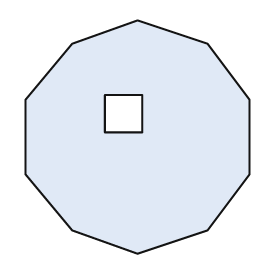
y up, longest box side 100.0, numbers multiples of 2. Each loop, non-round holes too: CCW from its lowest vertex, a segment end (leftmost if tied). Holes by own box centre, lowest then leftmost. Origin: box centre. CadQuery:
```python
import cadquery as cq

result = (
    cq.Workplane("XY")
    .moveTo(0.0, -50.0)
    .lineTo(30.0, -40.0)
    .lineTo(48.0, -16.0)
    .lineTo(48.0, 16.0)
    .lineTo(30.0, 40.0)
    .lineTo(0.0, 50.0)
    .lineTo(-28.0, 40.0)
    .lineTo(-48.0, 16.0)
    .lineTo(-48.0, -16.0)
    .lineTo(-28.0, -40.0)
    .close()
    .moveTo(-14.0, 2.0)
    .lineTo(2.0, 2.0)
    .lineTo(2.0, 18.0)
    .lineTo(-14.0, 18.0)
    .close()
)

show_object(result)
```